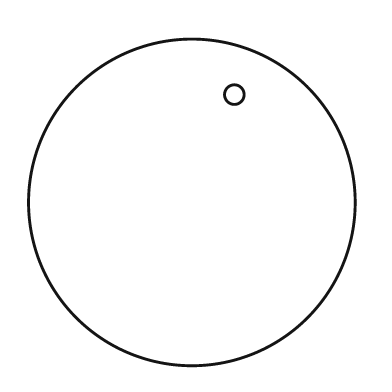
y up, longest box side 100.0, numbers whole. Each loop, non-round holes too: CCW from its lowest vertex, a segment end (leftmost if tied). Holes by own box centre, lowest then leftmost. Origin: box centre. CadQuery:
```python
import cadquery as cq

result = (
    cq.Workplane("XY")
    .moveTo(0.0, 0.0)
    .circle(50.0)
    .moveTo(13.0, 33.0)
    .circle(3.0)
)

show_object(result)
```